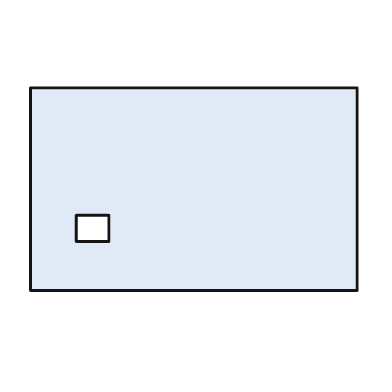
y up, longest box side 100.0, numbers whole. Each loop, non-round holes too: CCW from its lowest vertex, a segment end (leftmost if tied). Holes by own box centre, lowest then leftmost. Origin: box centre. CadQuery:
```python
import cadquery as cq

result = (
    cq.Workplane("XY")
    .moveTo(-50.0, -31.0)
    .lineTo(50.0, -31.0)
    .lineTo(50.0, 31.0)
    .lineTo(-50.0, 31.0)
    .close()
    .moveTo(-36.0, -16.0)
    .lineTo(-26.0, -16.0)
    .lineTo(-26.0, -8.0)
    .lineTo(-36.0, -8.0)
    .close()
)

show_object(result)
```